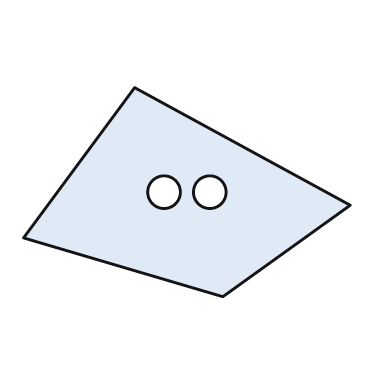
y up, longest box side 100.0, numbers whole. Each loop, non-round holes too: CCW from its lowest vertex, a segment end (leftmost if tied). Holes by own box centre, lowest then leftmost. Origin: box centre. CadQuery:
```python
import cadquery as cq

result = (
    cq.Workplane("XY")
    .moveTo(11.0, -32.0)
    .lineTo(50.0, -4.0)
    .lineTo(-16.0, 32.0)
    .lineTo(-50.0, -14.0)
    .close()
    .moveTo(-7.0, 0.0)
    .circle(5.0)
    .moveTo(7.0, 0.0)
    .circle(5.0)
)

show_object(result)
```